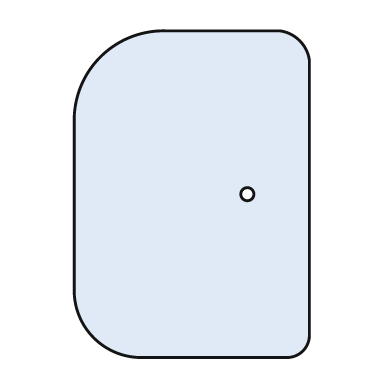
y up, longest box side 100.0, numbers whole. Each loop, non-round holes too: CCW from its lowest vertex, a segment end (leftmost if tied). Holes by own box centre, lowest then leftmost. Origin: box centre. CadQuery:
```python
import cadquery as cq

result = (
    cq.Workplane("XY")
    .moveTo(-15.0, -50.0)
    .lineTo(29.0, -50.0)
    .threePointArc((34.0, -48.0), (36.0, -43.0))
    .lineTo(36.0, 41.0)
    .threePointArc((33.0, 47.0), (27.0, 50.0))
    .lineTo(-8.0, 50.0)
    .threePointArc((-28.0, 42.0), (-36.0, 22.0))
    .lineTo(-36.0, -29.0)
    .threePointArc((-30.0, -44.0), (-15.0, -50.0))
    .close()
    .moveTo(17.0, 0.0)
    .circle(2.0)
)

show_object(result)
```